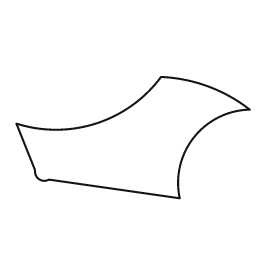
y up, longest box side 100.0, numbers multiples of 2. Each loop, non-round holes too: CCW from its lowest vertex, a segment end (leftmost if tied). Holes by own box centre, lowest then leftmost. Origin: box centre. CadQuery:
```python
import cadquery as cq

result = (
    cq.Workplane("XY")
    .moveTo(20.0, -26.0)
    .threePointArc((26.0, 0.0), (50.0, 12.0))
    .threePointArc((32.0, 22.0), (12.0, 26.0))
    .threePointArc((-16.0, 6.0), (-50.0, 6.0))
    .lineTo(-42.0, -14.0)
    .threePointArc((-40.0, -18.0), (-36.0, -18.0))
    .close()
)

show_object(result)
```